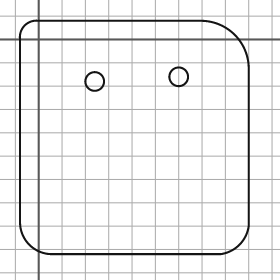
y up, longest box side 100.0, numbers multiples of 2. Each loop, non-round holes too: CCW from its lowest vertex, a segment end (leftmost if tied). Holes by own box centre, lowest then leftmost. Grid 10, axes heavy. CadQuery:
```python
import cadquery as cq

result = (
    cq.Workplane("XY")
    .moveTo(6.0, -92.0)
    .lineTo(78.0, -92.0)
    .threePointArc((86.0, -88.0), (90.0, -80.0))
    .lineTo(90.0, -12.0)
    .threePointArc((84.0, 2.0), (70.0, 8.0))
    .lineTo(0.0, 8.0)
    .threePointArc((-6.0, 6.0), (-8.0, 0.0))
    .lineTo(-8.0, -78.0)
    .threePointArc((-4.0, -88.0), (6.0, -92.0))
    .close()
    .moveTo(24.0, -18.0)
    .circle(4.0)
    .moveTo(60.0, -16.0)
    .circle(4.0)
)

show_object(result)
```